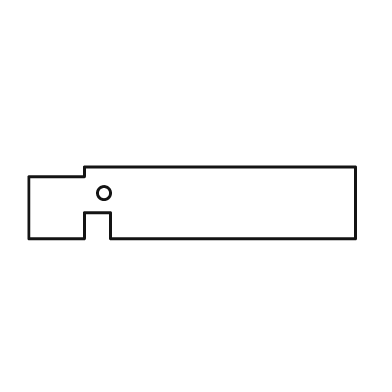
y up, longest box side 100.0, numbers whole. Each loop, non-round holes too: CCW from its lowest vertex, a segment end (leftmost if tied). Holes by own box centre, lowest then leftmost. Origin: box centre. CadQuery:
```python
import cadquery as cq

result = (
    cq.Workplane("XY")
    .moveTo(-50.0, -11.0)
    .lineTo(-33.0, -11.0)
    .lineTo(-33.0, -3.0)
    .lineTo(-25.0, -3.0)
    .lineTo(-25.0, -11.0)
    .lineTo(50.0, -11.0)
    .lineTo(50.0, 11.0)
    .lineTo(-33.0, 11.0)
    .lineTo(-33.0, 8.0)
    .lineTo(-50.0, 8.0)
    .close()
    .moveTo(-27.0, 3.0)
    .circle(2.0)
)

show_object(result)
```